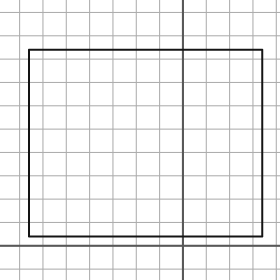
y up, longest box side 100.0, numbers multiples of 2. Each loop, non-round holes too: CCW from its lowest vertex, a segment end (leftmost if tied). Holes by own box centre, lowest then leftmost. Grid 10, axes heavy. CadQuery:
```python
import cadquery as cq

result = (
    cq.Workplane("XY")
    .moveTo(-66.0, 4.0)
    .lineTo(34.0, 4.0)
    .lineTo(34.0, 84.0)
    .lineTo(-66.0, 84.0)
    .close()
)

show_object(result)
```